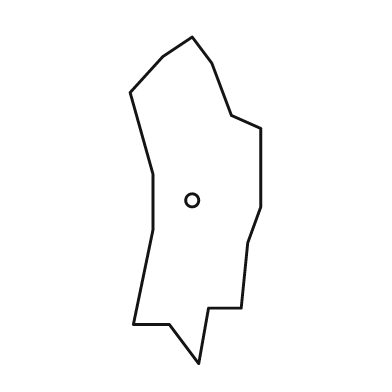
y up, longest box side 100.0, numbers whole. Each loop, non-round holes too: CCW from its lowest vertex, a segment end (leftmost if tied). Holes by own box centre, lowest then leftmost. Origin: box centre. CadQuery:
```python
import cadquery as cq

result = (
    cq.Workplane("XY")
    .moveTo(1.0, -50.0)
    .lineTo(4.0, -33.0)
    .lineTo(14.0, -33.0)
    .lineTo(16.0, -13.0)
    .lineTo(20.0, -2.0)
    .lineTo(20.0, 22.0)
    .lineTo(11.0, 26.0)
    .lineTo(5.0, 42.0)
    .lineTo(-1.0, 50.0)
    .lineTo(-10.0, 44.0)
    .lineTo(-20.0, 33.0)
    .lineTo(-13.0, 8.0)
    .lineTo(-13.0, -9.0)
    .lineTo(-19.0, -38.0)
    .lineTo(-8.0, -38.0)
    .close()
    .moveTo(-1.0, 0.0)
    .circle(2.0)
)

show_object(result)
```